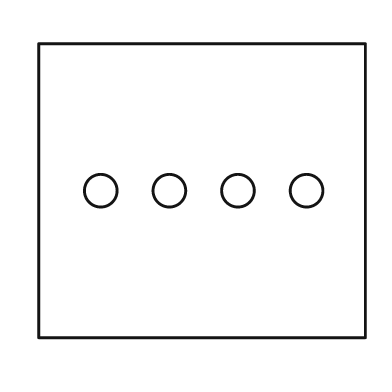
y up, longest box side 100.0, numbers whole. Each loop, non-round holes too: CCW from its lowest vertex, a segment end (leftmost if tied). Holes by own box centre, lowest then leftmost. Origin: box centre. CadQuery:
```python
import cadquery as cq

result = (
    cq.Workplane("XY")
    .moveTo(-50.0, -45.0)
    .lineTo(50.0, -45.0)
    .lineTo(50.0, 45.0)
    .lineTo(-50.0, 45.0)
    .close()
    .moveTo(-31.0, 0.0)
    .circle(5.0)
    .moveTo(-10.0, 0.0)
    .circle(5.0)
    .moveTo(11.0, 0.0)
    .circle(5.0)
    .moveTo(32.0, 0.0)
    .circle(5.0)
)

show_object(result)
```